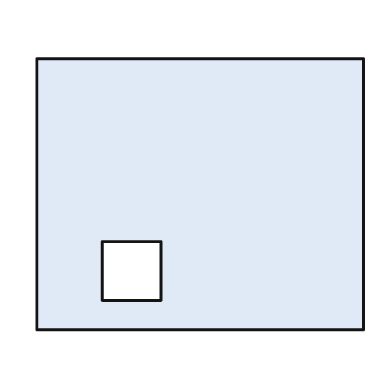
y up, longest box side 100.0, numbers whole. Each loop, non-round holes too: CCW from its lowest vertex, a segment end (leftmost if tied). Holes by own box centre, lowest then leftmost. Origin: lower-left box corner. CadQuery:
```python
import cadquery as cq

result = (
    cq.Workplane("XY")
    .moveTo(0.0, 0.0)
    .lineTo(100.0, 0.0)
    .lineTo(100.0, 83.0)
    .lineTo(0.0, 83.0)
    .close()
    .moveTo(20.0, 9.0)
    .lineTo(38.0, 9.0)
    .lineTo(38.0, 27.0)
    .lineTo(20.0, 27.0)
    .close()
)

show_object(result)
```